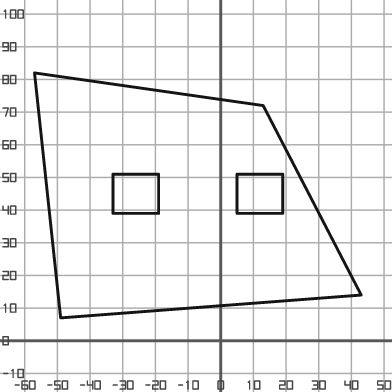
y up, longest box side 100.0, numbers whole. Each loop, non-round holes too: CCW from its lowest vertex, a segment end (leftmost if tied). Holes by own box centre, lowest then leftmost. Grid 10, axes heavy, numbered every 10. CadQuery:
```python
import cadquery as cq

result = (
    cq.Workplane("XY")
    .moveTo(-49.0, 7.0)
    .lineTo(43.0, 14.0)
    .lineTo(13.0, 72.0)
    .lineTo(-57.0, 82.0)
    .close()
    .moveTo(-33.0, 39.0)
    .lineTo(-19.0, 39.0)
    .lineTo(-19.0, 51.0)
    .lineTo(-33.0, 51.0)
    .close()
    .moveTo(5.0, 39.0)
    .lineTo(19.0, 39.0)
    .lineTo(19.0, 51.0)
    .lineTo(5.0, 51.0)
    .close()
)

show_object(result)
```